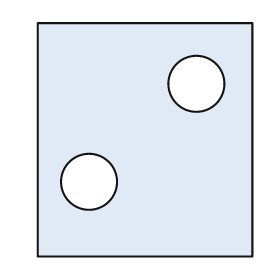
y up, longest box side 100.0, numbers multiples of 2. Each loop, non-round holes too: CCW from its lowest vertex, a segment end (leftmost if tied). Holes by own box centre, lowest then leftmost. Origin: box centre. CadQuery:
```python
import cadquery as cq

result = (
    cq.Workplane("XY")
    .moveTo(-46.0, -50.0)
    .lineTo(46.0, -50.0)
    .lineTo(46.0, 50.0)
    .lineTo(-46.0, 50.0)
    .close()
    .moveTo(-24.0, -18.0)
    .circle(12.0)
    .moveTo(22.0, 24.0)
    .circle(12.0)
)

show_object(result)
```